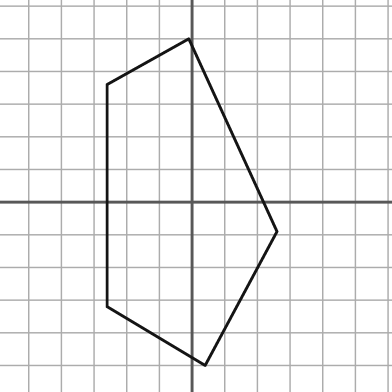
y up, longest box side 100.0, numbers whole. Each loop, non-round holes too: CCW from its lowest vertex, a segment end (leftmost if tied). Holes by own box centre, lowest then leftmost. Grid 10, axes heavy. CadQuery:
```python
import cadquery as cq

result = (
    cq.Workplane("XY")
    .moveTo(4.0, -50.0)
    .lineTo(26.0, -9.0)
    .lineTo(-1.0, 50.0)
    .lineTo(-26.0, 36.0)
    .lineTo(-26.0, -32.0)
    .close()
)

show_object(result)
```